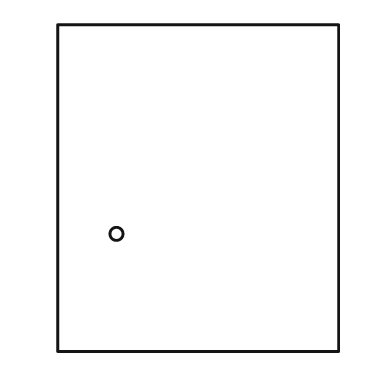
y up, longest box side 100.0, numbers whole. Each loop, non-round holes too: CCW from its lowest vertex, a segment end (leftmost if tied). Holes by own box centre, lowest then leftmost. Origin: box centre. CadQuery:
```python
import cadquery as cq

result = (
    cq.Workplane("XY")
    .moveTo(-43.0, -50.0)
    .lineTo(43.0, -50.0)
    .lineTo(43.0, 50.0)
    .lineTo(-43.0, 50.0)
    .close()
    .moveTo(-25.0, -14.0)
    .circle(2.0)
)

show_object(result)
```